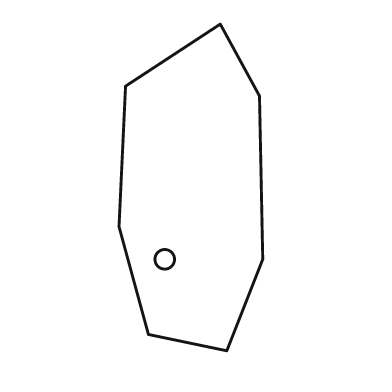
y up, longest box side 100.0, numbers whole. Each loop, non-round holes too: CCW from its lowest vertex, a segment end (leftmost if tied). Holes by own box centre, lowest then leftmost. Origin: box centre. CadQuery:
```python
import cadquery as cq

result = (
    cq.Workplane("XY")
    .moveTo(11.0, -50.0)
    .lineTo(22.0, -22.0)
    .lineTo(21.0, 28.0)
    .lineTo(9.0, 50.0)
    .lineTo(-20.0, 31.0)
    .lineTo(-22.0, -12.0)
    .lineTo(-13.0, -45.0)
    .close()
    .moveTo(-8.0, -22.0)
    .circle(3.0)
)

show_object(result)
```